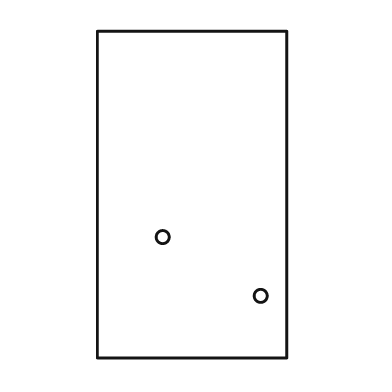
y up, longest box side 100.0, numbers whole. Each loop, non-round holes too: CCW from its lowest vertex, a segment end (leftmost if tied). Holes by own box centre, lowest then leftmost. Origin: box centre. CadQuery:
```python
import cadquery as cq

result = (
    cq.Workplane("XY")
    .moveTo(-29.0, -50.0)
    .lineTo(29.0, -50.0)
    .lineTo(29.0, 50.0)
    .lineTo(-29.0, 50.0)
    .close()
    .moveTo(21.0, -31.0)
    .circle(2.0)
    .moveTo(-9.0, -13.0)
    .circle(2.0)
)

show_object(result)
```